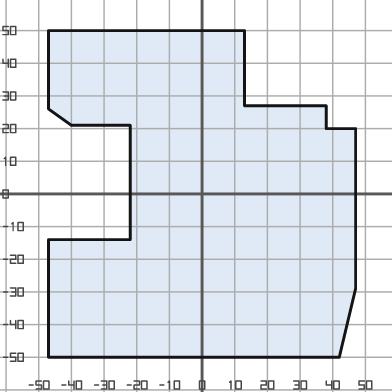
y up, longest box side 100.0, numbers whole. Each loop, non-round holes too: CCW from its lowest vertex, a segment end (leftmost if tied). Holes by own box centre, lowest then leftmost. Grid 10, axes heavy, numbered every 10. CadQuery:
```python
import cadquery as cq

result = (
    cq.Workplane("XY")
    .moveTo(-47.0, -50.0)
    .lineTo(42.0, -50.0)
    .lineTo(47.0, -29.0)
    .lineTo(47.0, 20.0)
    .lineTo(38.0, 20.0)
    .lineTo(38.0, 27.0)
    .lineTo(13.0, 27.0)
    .lineTo(13.0, 50.0)
    .lineTo(-47.0, 50.0)
    .lineTo(-47.0, 26.0)
    .lineTo(-40.0, 21.0)
    .lineTo(-22.0, 21.0)
    .lineTo(-22.0, -14.0)
    .lineTo(-47.0, -14.0)
    .close()
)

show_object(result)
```